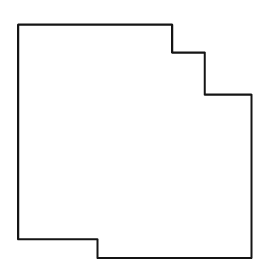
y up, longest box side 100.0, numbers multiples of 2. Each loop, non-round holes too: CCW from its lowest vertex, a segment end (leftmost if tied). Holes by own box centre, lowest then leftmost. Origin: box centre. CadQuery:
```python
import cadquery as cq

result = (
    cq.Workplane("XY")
    .moveTo(-16.0, -50.0)
    .lineTo(50.0, -50.0)
    .lineTo(50.0, 20.0)
    .lineTo(30.0, 20.0)
    .lineTo(30.0, 38.0)
    .lineTo(16.0, 38.0)
    .lineTo(16.0, 50.0)
    .lineTo(-50.0, 50.0)
    .lineTo(-50.0, -42.0)
    .lineTo(-16.0, -42.0)
    .close()
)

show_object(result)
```